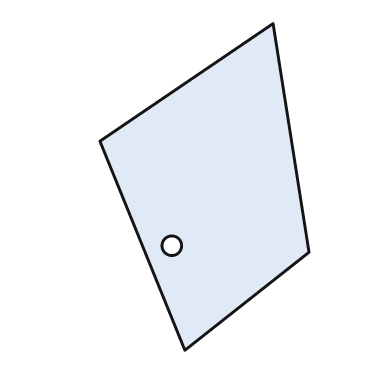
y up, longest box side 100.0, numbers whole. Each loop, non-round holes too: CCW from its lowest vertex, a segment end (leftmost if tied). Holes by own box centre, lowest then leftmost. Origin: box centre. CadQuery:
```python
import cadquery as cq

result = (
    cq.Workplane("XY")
    .moveTo(-6.0, -50.0)
    .lineTo(32.0, -20.0)
    .lineTo(21.0, 50.0)
    .lineTo(-32.0, 14.0)
    .close()
    .moveTo(-10.0, -18.0)
    .circle(3.0)
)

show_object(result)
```